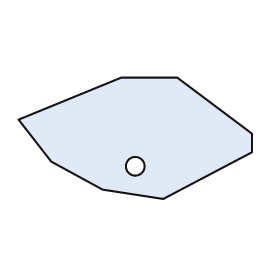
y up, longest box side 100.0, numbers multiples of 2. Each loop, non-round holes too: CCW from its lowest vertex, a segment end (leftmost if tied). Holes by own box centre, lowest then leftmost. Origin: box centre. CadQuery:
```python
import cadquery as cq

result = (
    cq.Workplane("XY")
    .moveTo(12.0, -26.0)
    .lineTo(50.0, -6.0)
    .lineTo(50.0, 2.0)
    .lineTo(18.0, 26.0)
    .lineTo(-6.0, 26.0)
    .lineTo(-50.0, 8.0)
    .lineTo(-36.0, -10.0)
    .lineTo(-14.0, -22.0)
    .close()
    .moveTo(0.0, -12.0)
    .circle(4.0)
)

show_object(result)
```